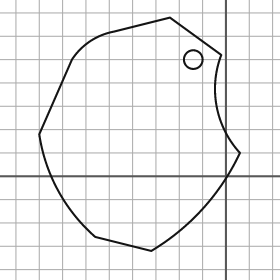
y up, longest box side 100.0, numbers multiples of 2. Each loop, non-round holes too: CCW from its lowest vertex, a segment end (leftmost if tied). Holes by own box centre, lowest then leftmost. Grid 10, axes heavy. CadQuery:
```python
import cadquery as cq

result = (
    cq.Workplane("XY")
    .moveTo(-32.0, -32.0)
    .threePointArc((-10.0, -14.0), (6.0, 10.0))
    .threePointArc((-4.0, 30.0), (-2.0, 52.0))
    .lineTo(-24.0, 68.0)
    .lineTo(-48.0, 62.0)
    .threePointArc((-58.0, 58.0), (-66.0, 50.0))
    .lineTo(-80.0, 18.0)
    .threePointArc((-72.0, -6.0), (-56.0, -26.0))
    .close()
    .moveTo(-14.0, 50.0)
    .circle(4.0)
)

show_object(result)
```